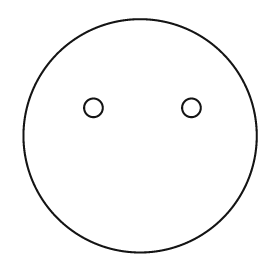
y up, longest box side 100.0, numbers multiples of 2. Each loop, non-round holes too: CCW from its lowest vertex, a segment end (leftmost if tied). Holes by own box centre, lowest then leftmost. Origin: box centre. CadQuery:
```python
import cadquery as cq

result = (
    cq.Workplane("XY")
    .moveTo(0.0, 0.0)
    .circle(50.0)
    .moveTo(-20.0, 12.0)
    .circle(4.0)
    .moveTo(22.0, 12.0)
    .circle(4.0)
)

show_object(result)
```